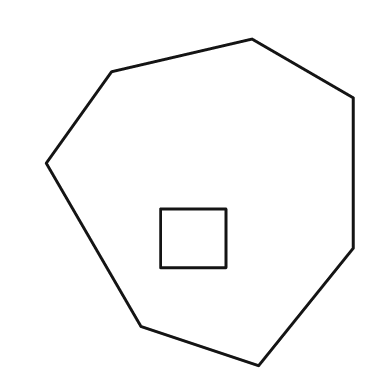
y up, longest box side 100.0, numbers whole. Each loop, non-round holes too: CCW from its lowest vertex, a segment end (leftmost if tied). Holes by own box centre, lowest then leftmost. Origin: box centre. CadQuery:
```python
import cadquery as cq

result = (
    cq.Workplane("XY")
    .moveTo(18.0, -50.0)
    .lineTo(47.0, -14.0)
    .lineTo(47.0, 32.0)
    .lineTo(16.0, 50.0)
    .lineTo(-27.0, 40.0)
    .lineTo(-47.0, 12.0)
    .lineTo(-18.0, -38.0)
    .close()
    .moveTo(-12.0, -20.0)
    .lineTo(8.0, -20.0)
    .lineTo(8.0, -2.0)
    .lineTo(-12.0, -2.0)
    .close()
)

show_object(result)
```